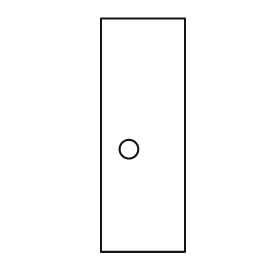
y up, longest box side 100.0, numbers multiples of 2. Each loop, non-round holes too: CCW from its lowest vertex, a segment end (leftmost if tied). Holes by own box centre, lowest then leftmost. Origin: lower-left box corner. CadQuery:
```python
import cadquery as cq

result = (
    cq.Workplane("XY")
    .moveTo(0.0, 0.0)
    .lineTo(36.0, 0.0)
    .lineTo(36.0, 100.0)
    .lineTo(0.0, 100.0)
    .close()
    .moveTo(12.0, 44.0)
    .circle(4.0)
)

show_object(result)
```